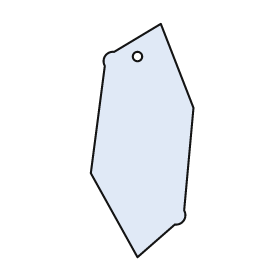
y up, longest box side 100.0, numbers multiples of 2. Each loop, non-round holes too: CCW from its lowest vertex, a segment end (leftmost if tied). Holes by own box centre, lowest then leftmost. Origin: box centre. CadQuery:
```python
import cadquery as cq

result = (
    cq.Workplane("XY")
    .moveTo(-2.0, -50.0)
    .lineTo(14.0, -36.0)
    .threePointArc((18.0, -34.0), (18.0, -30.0))
    .lineTo(22.0, 14.0)
    .lineTo(8.0, 50.0)
    .lineTo(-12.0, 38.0)
    .threePointArc((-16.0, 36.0), (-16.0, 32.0))
    .lineTo(-22.0, -14.0)
    .close()
    .moveTo(-2.0, 36.0)
    .circle(2.0)
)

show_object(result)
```